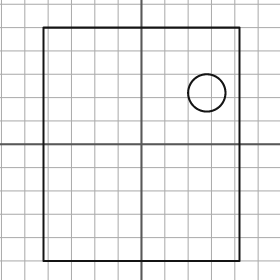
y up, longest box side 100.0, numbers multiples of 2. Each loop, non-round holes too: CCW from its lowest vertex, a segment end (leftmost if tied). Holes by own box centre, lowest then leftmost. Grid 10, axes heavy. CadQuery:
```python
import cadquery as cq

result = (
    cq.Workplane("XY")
    .moveTo(-42.0, -50.0)
    .lineTo(42.0, -50.0)
    .lineTo(42.0, 50.0)
    .lineTo(-42.0, 50.0)
    .close()
    .moveTo(28.0, 22.0)
    .circle(8.0)
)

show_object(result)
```